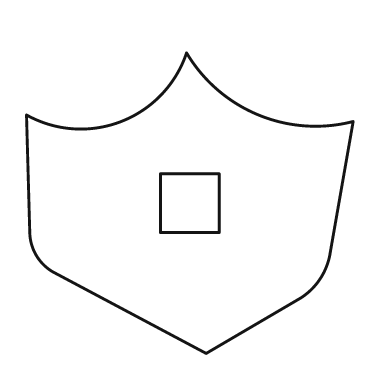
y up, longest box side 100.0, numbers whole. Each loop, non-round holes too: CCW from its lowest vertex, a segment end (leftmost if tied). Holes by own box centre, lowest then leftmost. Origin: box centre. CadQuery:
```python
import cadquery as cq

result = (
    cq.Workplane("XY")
    .moveTo(5.0, -46.0)
    .lineTo(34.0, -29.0)
    .threePointArc((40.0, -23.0), (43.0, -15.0))
    .lineTo(50.0, 25.0)
    .threePointArc((21.0, 27.0), (-1.0, 46.0))
    .threePointArc((-21.0, 25.0), (-50.0, 27.0))
    .lineTo(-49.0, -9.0)
    .threePointArc((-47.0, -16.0), (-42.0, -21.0))
    .close()
    .moveTo(-9.0, -9.0)
    .lineTo(9.0, -9.0)
    .lineTo(9.0, 9.0)
    .lineTo(-9.0, 9.0)
    .close()
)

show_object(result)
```